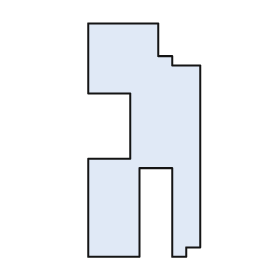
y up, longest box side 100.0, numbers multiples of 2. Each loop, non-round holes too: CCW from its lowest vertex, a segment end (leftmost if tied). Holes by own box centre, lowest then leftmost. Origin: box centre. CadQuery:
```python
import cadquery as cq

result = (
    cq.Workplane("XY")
    .moveTo(-24.0, -50.0)
    .lineTo(-2.0, -50.0)
    .lineTo(-2.0, -12.0)
    .lineTo(12.0, -12.0)
    .lineTo(12.0, -50.0)
    .lineTo(18.0, -50.0)
    .lineTo(18.0, -46.0)
    .lineTo(24.0, -46.0)
    .lineTo(24.0, 32.0)
    .lineTo(12.0, 32.0)
    .lineTo(12.0, 36.0)
    .lineTo(6.0, 36.0)
    .lineTo(6.0, 50.0)
    .lineTo(-24.0, 50.0)
    .lineTo(-24.0, 20.0)
    .lineTo(-6.0, 20.0)
    .lineTo(-6.0, -8.0)
    .lineTo(-24.0, -8.0)
    .close()
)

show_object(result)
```